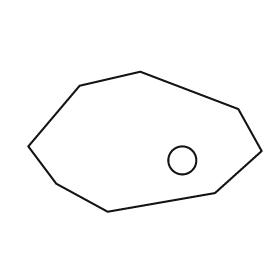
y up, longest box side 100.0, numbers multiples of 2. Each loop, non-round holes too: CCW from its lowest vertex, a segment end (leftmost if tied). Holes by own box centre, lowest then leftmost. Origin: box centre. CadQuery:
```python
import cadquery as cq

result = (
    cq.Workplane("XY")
    .moveTo(-16.0, -30.0)
    .lineTo(30.0, -22.0)
    .lineTo(50.0, -4.0)
    .lineTo(40.0, 14.0)
    .lineTo(-2.0, 30.0)
    .lineTo(-28.0, 24.0)
    .lineTo(-50.0, -2.0)
    .lineTo(-38.0, -18.0)
    .close()
    .moveTo(16.0, -8.0)
    .circle(6.0)
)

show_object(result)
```